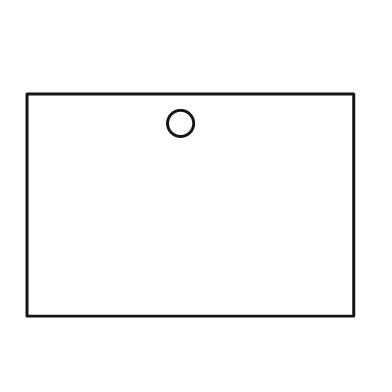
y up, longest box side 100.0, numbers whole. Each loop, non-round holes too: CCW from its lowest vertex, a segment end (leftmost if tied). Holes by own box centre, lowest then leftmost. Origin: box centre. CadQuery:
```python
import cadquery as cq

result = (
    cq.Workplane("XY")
    .moveTo(-50.0, -34.0)
    .lineTo(50.0, -34.0)
    .lineTo(50.0, 34.0)
    .lineTo(-50.0, 34.0)
    .close()
    .moveTo(-3.0, 25.0)
    .circle(4.0)
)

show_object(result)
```